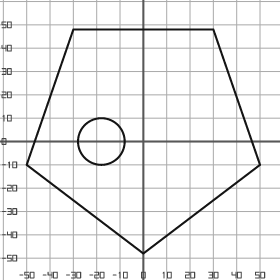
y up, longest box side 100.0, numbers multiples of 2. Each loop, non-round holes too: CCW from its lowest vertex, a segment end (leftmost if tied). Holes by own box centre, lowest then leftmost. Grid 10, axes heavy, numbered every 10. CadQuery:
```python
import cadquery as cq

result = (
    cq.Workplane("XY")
    .moveTo(0.0, -48.0)
    .lineTo(50.0, -10.0)
    .lineTo(30.0, 48.0)
    .lineTo(-30.0, 48.0)
    .lineTo(-50.0, -10.0)
    .close()
    .moveTo(-18.0, 0.0)
    .circle(10.0)
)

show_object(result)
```